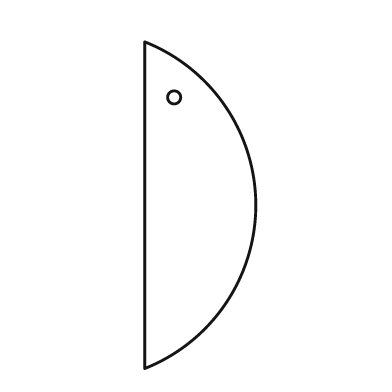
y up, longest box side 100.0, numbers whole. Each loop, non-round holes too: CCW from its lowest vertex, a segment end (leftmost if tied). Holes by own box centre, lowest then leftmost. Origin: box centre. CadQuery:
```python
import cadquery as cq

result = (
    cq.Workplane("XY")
    .moveTo(-17.0, -50.0)
    .threePointArc((17.0, 0.0), (-17.0, 50.0))
    .close()
    .moveTo(-8.0, 33.0)
    .circle(2.0)
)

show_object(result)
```